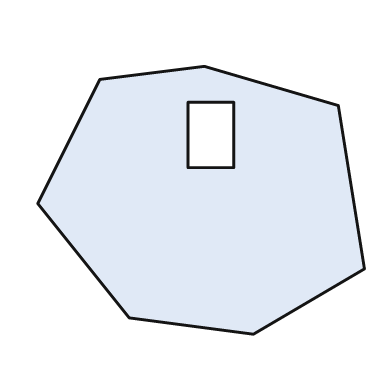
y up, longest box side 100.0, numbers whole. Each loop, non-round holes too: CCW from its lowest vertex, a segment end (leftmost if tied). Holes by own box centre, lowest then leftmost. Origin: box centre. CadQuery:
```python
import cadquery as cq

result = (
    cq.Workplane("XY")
    .moveTo(16.0, -41.0)
    .lineTo(50.0, -21.0)
    .lineTo(42.0, 29.0)
    .lineTo(1.0, 41.0)
    .lineTo(-31.0, 37.0)
    .lineTo(-50.0, -1.0)
    .lineTo(-22.0, -36.0)
    .close()
    .moveTo(-4.0, 10.0)
    .lineTo(10.0, 10.0)
    .lineTo(10.0, 30.0)
    .lineTo(-4.0, 30.0)
    .close()
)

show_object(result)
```